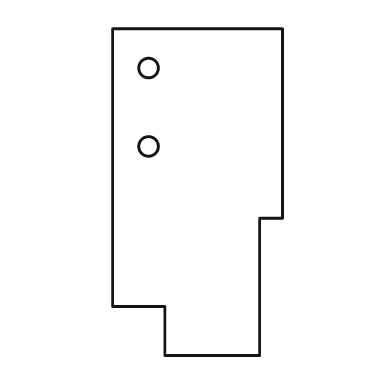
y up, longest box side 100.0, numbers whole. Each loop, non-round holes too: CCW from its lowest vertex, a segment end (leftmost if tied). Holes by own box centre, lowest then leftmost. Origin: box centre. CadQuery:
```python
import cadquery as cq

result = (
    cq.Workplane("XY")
    .moveTo(-10.0, -50.0)
    .lineTo(19.0, -50.0)
    .lineTo(19.0, -8.0)
    .lineTo(26.0, -8.0)
    .lineTo(26.0, 50.0)
    .lineTo(-26.0, 50.0)
    .lineTo(-26.0, -35.0)
    .lineTo(-10.0, -35.0)
    .close()
    .moveTo(-15.0, 14.0)
    .circle(3.0)
    .moveTo(-15.0, 38.0)
    .circle(3.0)
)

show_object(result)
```